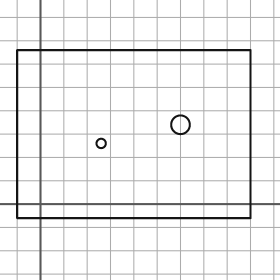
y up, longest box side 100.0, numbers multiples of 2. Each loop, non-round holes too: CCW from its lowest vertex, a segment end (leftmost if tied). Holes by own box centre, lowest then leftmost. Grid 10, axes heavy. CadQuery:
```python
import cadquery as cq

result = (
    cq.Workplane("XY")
    .moveTo(-10.0, -6.0)
    .lineTo(90.0, -6.0)
    .lineTo(90.0, 66.0)
    .lineTo(-10.0, 66.0)
    .close()
    .moveTo(26.0, 26.0)
    .circle(2.0)
    .moveTo(60.0, 34.0)
    .circle(4.0)
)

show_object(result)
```